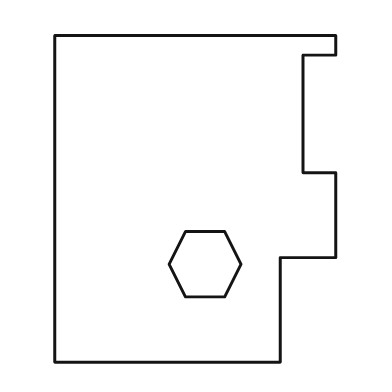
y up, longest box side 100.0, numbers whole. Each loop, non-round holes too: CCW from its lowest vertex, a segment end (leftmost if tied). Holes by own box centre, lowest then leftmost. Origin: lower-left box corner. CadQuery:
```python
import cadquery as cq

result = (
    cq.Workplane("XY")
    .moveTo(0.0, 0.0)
    .lineTo(69.0, 0.0)
    .lineTo(69.0, 32.0)
    .lineTo(86.0, 32.0)
    .lineTo(86.0, 58.0)
    .lineTo(76.0, 58.0)
    .lineTo(76.0, 94.0)
    .lineTo(86.0, 94.0)
    .lineTo(86.0, 100.0)
    .lineTo(0.0, 100.0)
    .close()
    .moveTo(40.0, 20.0)
    .lineTo(52.0, 20.0)
    .lineTo(57.0, 30.0)
    .lineTo(52.0, 40.0)
    .lineTo(40.0, 40.0)
    .lineTo(35.0, 30.0)
    .close()
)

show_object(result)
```